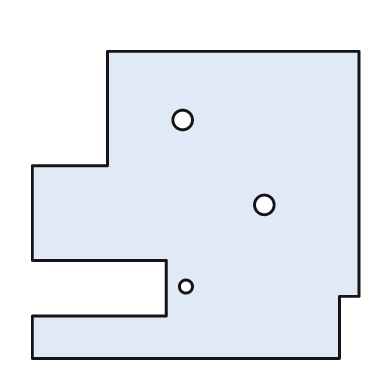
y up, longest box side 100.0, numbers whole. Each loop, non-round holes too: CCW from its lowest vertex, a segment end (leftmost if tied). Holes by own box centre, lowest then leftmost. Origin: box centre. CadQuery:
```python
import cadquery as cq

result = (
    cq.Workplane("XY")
    .moveTo(-50.0, -47.0)
    .lineTo(44.0, -47.0)
    .lineTo(44.0, -28.0)
    .lineTo(50.0, -28.0)
    .lineTo(50.0, 47.0)
    .lineTo(-27.0, 47.0)
    .lineTo(-27.0, 12.0)
    .lineTo(-50.0, 12.0)
    .lineTo(-50.0, -17.0)
    .lineTo(-9.0, -17.0)
    .lineTo(-9.0, -34.0)
    .lineTo(-50.0, -34.0)
    .close()
    .moveTo(-3.0, -25.0)
    .circle(2.0)
    .moveTo(21.0, 0.0)
    .circle(3.0)
    .moveTo(-4.0, 26.0)
    .circle(3.0)
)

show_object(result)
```